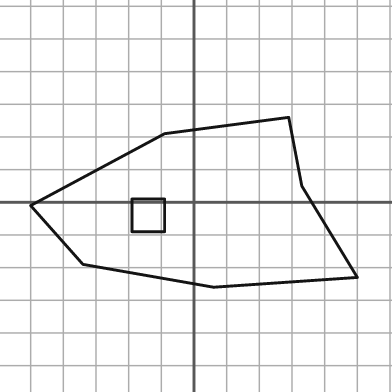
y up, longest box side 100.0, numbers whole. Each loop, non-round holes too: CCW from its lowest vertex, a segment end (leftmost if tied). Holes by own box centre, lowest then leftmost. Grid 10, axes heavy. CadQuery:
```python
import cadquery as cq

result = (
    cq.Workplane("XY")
    .moveTo(6.0, -26.0)
    .lineTo(50.0, -23.0)
    .lineTo(33.0, 5.0)
    .lineTo(29.0, 26.0)
    .lineTo(-9.0, 21.0)
    .lineTo(-50.0, -1.0)
    .lineTo(-34.0, -19.0)
    .close()
    .moveTo(-19.0, -9.0)
    .lineTo(-9.0, -9.0)
    .lineTo(-9.0, 1.0)
    .lineTo(-19.0, 1.0)
    .close()
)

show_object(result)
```